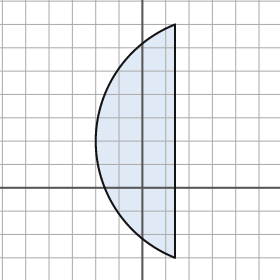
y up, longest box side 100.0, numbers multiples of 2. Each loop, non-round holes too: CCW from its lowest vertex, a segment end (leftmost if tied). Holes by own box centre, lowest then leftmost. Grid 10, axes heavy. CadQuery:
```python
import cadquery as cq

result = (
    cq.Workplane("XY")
    .moveTo(14.0, -30.0)
    .lineTo(14.0, 70.0)
    .threePointArc((-20.0, 20.0), (14.0, -30.0))
    .close()
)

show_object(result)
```